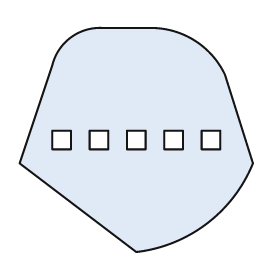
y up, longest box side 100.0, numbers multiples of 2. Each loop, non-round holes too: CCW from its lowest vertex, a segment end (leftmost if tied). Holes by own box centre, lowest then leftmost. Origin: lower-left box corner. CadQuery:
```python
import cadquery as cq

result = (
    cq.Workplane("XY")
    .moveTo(50.0, 0.0)
    .threePointArc((80.0, 12.0), (100.0, 38.0))
    .lineTo(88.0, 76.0)
    .threePointArc((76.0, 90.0), (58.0, 96.0))
    .lineTo(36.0, 96.0)
    .threePointArc((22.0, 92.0), (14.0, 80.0))
    .lineTo(0.0, 38.0)
    .close()
    .moveTo(14.0, 44.0)
    .lineTo(22.0, 44.0)
    .lineTo(22.0, 52.0)
    .lineTo(14.0, 52.0)
    .close()
    .moveTo(30.0, 44.0)
    .lineTo(38.0, 44.0)
    .lineTo(38.0, 52.0)
    .lineTo(30.0, 52.0)
    .close()
    .moveTo(46.0, 44.0)
    .lineTo(54.0, 44.0)
    .lineTo(54.0, 52.0)
    .lineTo(46.0, 52.0)
    .close()
    .moveTo(62.0, 44.0)
    .lineTo(70.0, 44.0)
    .lineTo(70.0, 52.0)
    .lineTo(62.0, 52.0)
    .close()
    .moveTo(78.0, 44.0)
    .lineTo(86.0, 44.0)
    .lineTo(86.0, 52.0)
    .lineTo(78.0, 52.0)
    .close()
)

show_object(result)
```